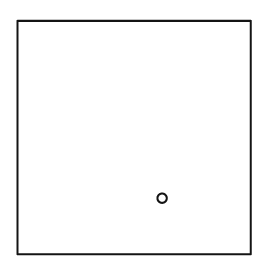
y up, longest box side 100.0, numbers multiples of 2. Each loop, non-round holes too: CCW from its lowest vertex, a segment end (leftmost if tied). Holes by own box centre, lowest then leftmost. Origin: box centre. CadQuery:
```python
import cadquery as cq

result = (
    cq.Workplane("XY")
    .moveTo(-50.0, -50.0)
    .lineTo(50.0, -50.0)
    .lineTo(50.0, 50.0)
    .lineTo(-50.0, 50.0)
    .close()
    .moveTo(12.0, -26.0)
    .circle(2.0)
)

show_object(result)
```